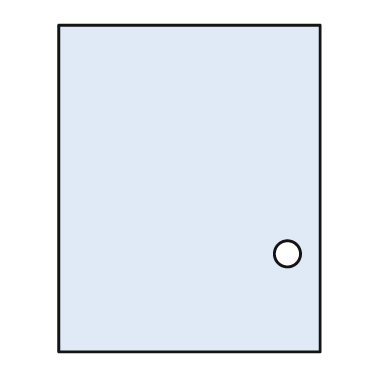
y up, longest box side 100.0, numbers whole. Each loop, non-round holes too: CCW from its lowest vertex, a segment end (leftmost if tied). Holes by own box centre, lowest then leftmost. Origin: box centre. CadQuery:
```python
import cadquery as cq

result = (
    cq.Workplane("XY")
    .moveTo(-40.0, -50.0)
    .lineTo(40.0, -50.0)
    .lineTo(40.0, 50.0)
    .lineTo(-40.0, 50.0)
    .close()
    .moveTo(30.0, -20.0)
    .circle(4.0)
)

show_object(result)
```